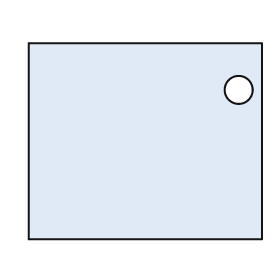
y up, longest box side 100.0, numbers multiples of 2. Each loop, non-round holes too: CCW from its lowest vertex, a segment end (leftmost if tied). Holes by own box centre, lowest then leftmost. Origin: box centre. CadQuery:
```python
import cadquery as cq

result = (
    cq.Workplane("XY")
    .moveTo(-50.0, -42.0)
    .lineTo(50.0, -42.0)
    .lineTo(50.0, 42.0)
    .lineTo(-50.0, 42.0)
    .close()
    .moveTo(40.0, 22.0)
    .circle(6.0)
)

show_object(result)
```